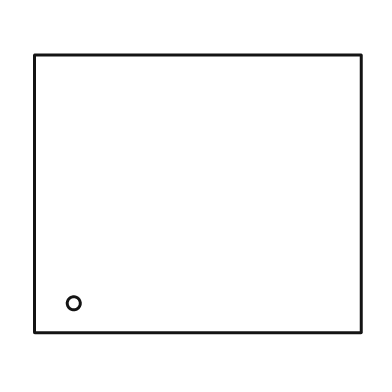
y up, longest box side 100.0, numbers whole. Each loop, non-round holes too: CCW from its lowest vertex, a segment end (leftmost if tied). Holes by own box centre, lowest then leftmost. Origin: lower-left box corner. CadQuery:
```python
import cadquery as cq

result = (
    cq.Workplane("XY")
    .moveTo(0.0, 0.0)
    .lineTo(100.0, 0.0)
    .lineTo(100.0, 85.0)
    .lineTo(0.0, 85.0)
    .close()
    .moveTo(12.0, 9.0)
    .circle(2.0)
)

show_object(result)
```